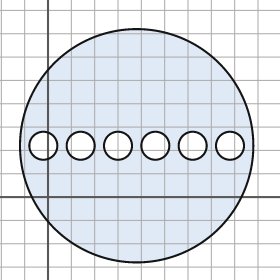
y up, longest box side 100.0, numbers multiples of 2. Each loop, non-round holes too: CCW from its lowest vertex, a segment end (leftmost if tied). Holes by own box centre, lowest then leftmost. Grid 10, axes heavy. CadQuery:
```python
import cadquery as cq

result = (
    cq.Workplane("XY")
    .moveTo(38.0, 22.0)
    .circle(50.0)
    .moveTo(-2.0, 22.0)
    .circle(6.0)
    .moveTo(14.0, 22.0)
    .circle(6.0)
    .moveTo(30.0, 22.0)
    .circle(6.0)
    .moveTo(46.0, 22.0)
    .circle(6.0)
    .moveTo(62.0, 22.0)
    .circle(6.0)
    .moveTo(78.0, 22.0)
    .circle(6.0)
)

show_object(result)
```